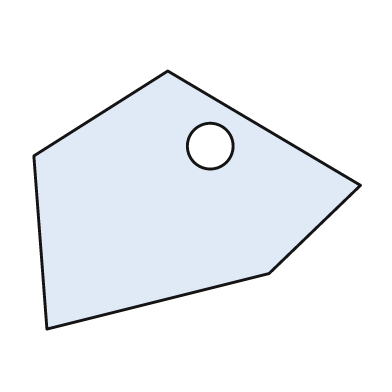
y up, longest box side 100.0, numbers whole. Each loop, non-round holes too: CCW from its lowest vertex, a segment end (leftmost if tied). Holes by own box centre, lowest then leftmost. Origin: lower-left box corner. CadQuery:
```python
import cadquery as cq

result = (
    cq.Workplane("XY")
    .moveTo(4.0, 0.0)
    .lineTo(72.0, 17.0)
    .lineTo(100.0, 44.0)
    .lineTo(41.0, 79.0)
    .lineTo(0.0, 53.0)
    .close()
    .moveTo(54.0, 56.0)
    .circle(7.0)
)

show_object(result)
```